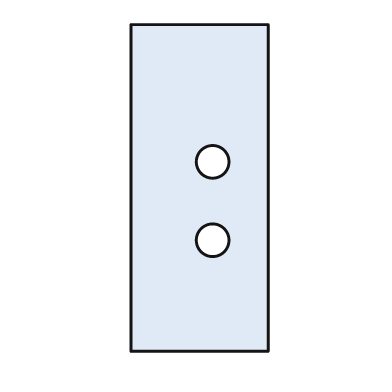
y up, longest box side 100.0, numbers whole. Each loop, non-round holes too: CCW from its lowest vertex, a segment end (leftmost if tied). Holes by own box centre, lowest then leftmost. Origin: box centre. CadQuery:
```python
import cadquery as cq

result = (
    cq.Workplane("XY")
    .moveTo(-21.0, -50.0)
    .lineTo(21.0, -50.0)
    .lineTo(21.0, 50.0)
    .lineTo(-21.0, 50.0)
    .close()
    .moveTo(4.0, -16.0)
    .circle(5.0)
    .moveTo(4.0, 8.0)
    .circle(5.0)
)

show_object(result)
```